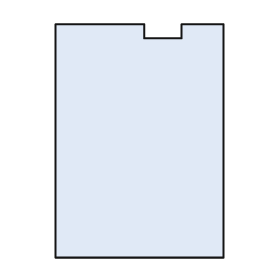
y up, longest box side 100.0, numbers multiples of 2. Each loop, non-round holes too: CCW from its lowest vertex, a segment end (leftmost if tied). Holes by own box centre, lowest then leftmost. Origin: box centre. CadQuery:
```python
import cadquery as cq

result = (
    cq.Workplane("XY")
    .moveTo(-36.0, -50.0)
    .lineTo(36.0, -50.0)
    .lineTo(36.0, 50.0)
    .lineTo(18.0, 50.0)
    .lineTo(18.0, 44.0)
    .lineTo(2.0, 44.0)
    .lineTo(2.0, 50.0)
    .lineTo(-36.0, 50.0)
    .close()
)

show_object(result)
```